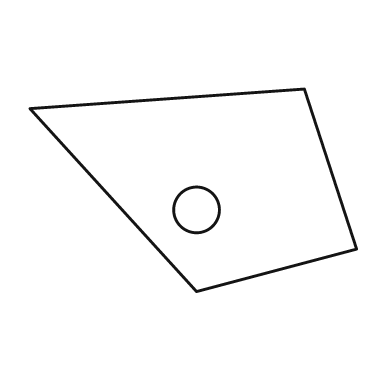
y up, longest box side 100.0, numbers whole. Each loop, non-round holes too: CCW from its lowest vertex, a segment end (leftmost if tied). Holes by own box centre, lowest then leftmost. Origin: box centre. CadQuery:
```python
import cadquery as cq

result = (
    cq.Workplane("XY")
    .moveTo(1.0, -31.0)
    .lineTo(50.0, -18.0)
    .lineTo(34.0, 31.0)
    .lineTo(-50.0, 25.0)
    .close()
    .moveTo(1.0, -6.0)
    .circle(7.0)
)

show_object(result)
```